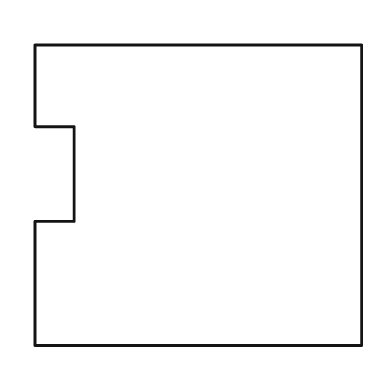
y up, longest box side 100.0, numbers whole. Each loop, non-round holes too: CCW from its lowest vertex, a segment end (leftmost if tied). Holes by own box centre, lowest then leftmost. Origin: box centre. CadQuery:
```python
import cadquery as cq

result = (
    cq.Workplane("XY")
    .moveTo(-50.0, -46.0)
    .lineTo(50.0, -46.0)
    .lineTo(50.0, 46.0)
    .lineTo(-50.0, 46.0)
    .lineTo(-50.0, 21.0)
    .lineTo(-38.0, 21.0)
    .lineTo(-38.0, -8.0)
    .lineTo(-50.0, -8.0)
    .close()
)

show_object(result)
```